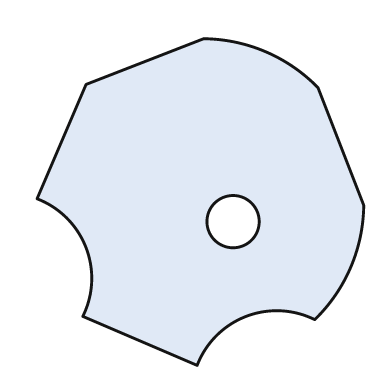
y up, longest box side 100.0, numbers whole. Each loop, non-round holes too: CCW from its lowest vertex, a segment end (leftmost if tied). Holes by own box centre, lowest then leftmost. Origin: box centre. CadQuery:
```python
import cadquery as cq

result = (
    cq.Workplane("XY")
    .moveTo(-1.0, -50.0)
    .threePointArc((14.0, -35.0), (35.0, -36.0))
    .threePointArc((46.0, -20.0), (50.0, -1.0))
    .lineTo(36.0, 35.0)
    .threePointArc((20.0, 46.0), (1.0, 50.0))
    .lineTo(-35.0, 36.0)
    .lineTo(-50.0, 1.0)
    .threePointArc((-35.0, -14.0), (-36.0, -35.0))
    .close()
    .moveTo(10.0, -6.0)
    .circle(8.0)
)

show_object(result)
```